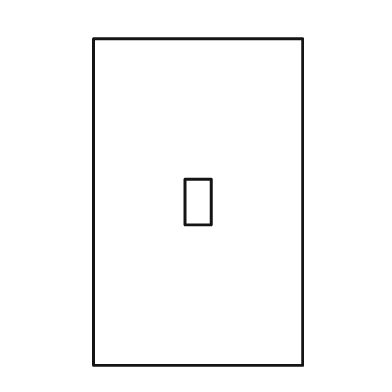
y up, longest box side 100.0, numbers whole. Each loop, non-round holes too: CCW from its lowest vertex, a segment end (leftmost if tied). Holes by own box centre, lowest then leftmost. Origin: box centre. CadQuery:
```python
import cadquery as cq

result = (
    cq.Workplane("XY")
    .moveTo(-32.0, -50.0)
    .lineTo(32.0, -50.0)
    .lineTo(32.0, 50.0)
    .lineTo(-32.0, 50.0)
    .close()
    .moveTo(-4.0, -7.0)
    .lineTo(4.0, -7.0)
    .lineTo(4.0, 7.0)
    .lineTo(-4.0, 7.0)
    .close()
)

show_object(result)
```